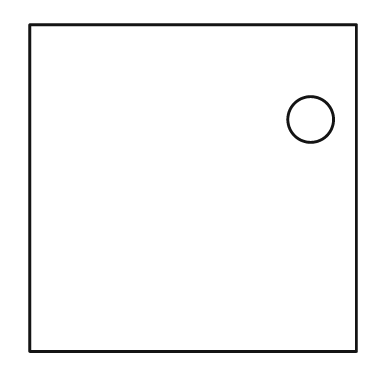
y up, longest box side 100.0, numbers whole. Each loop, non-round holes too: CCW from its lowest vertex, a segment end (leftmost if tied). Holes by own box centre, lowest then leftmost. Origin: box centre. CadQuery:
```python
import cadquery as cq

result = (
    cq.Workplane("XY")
    .moveTo(-50.0, -50.0)
    .lineTo(50.0, -50.0)
    .lineTo(50.0, 50.0)
    .lineTo(-50.0, 50.0)
    .close()
    .moveTo(36.0, 21.0)
    .circle(7.0)
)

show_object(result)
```